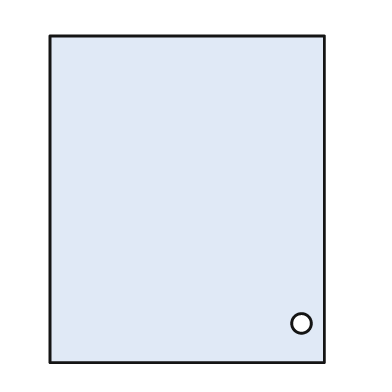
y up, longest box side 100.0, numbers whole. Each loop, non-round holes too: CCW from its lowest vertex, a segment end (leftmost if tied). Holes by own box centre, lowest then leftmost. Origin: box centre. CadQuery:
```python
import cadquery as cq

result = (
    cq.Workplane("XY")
    .moveTo(-42.0, -50.0)
    .lineTo(42.0, -50.0)
    .lineTo(42.0, 50.0)
    .lineTo(-42.0, 50.0)
    .close()
    .moveTo(35.0, -38.0)
    .circle(3.0)
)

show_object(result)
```